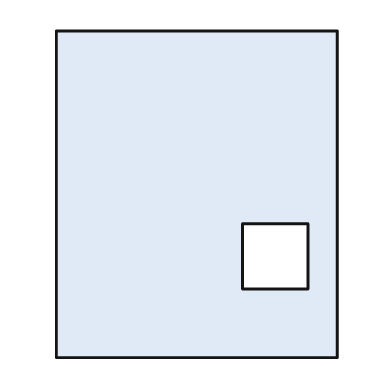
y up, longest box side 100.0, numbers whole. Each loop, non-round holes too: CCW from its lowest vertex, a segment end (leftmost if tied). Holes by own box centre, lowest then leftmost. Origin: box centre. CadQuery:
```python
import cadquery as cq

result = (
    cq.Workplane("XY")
    .moveTo(-43.0, -50.0)
    .lineTo(43.0, -50.0)
    .lineTo(43.0, 50.0)
    .lineTo(-43.0, 50.0)
    .close()
    .moveTo(14.0, -29.0)
    .lineTo(34.0, -29.0)
    .lineTo(34.0, -9.0)
    .lineTo(14.0, -9.0)
    .close()
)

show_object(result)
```